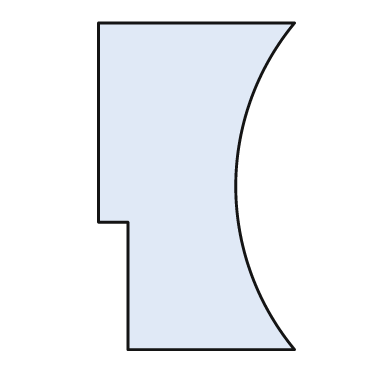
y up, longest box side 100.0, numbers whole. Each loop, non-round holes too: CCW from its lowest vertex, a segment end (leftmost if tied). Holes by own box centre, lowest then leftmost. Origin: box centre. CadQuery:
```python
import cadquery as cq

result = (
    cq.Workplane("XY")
    .moveTo(-21.0, -50.0)
    .lineTo(30.0, -50.0)
    .threePointArc((12.0, 0.0), (30.0, 50.0))
    .lineTo(-30.0, 50.0)
    .lineTo(-30.0, -11.0)
    .lineTo(-21.0, -11.0)
    .close()
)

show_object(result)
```